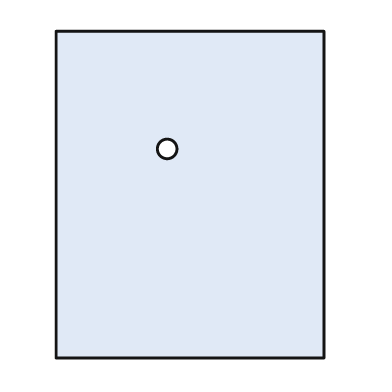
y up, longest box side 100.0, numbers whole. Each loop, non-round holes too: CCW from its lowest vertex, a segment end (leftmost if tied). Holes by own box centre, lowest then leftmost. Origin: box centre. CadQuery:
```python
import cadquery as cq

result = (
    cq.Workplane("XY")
    .moveTo(-41.0, -50.0)
    .lineTo(41.0, -50.0)
    .lineTo(41.0, 50.0)
    .lineTo(-41.0, 50.0)
    .close()
    .moveTo(-7.0, 14.0)
    .circle(3.0)
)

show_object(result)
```